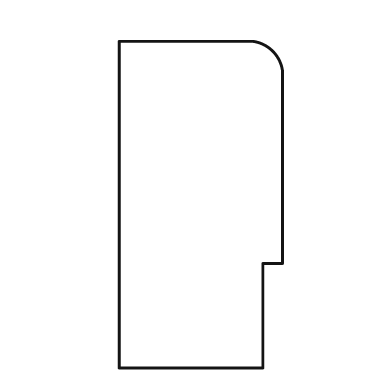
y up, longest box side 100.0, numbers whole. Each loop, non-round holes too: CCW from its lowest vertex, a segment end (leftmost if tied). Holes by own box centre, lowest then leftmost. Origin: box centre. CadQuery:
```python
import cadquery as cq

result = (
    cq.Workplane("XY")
    .moveTo(-25.0, -50.0)
    .lineTo(19.0, -50.0)
    .lineTo(19.0, -18.0)
    .lineTo(25.0, -18.0)
    .lineTo(25.0, 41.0)
    .threePointArc((22.0, 47.0), (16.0, 50.0))
    .lineTo(-25.0, 50.0)
    .close()
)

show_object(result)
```